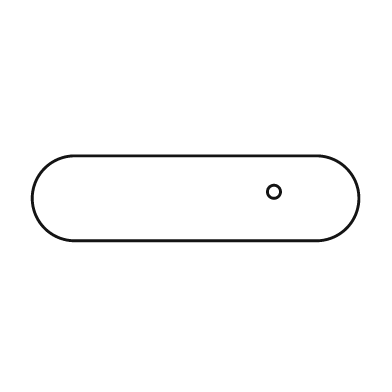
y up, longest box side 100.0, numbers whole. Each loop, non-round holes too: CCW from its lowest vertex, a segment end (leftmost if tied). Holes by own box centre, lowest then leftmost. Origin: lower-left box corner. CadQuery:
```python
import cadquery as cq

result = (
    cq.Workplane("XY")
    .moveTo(13.0, 0.0)
    .lineTo(87.0, 0.0)
    .threePointArc((100.0, 13.0), (87.0, 26.0))
    .lineTo(13.0, 26.0)
    .threePointArc((0.0, 13.0), (13.0, 0.0))
    .close()
    .moveTo(74.0, 15.0)
    .circle(2.0)
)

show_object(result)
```